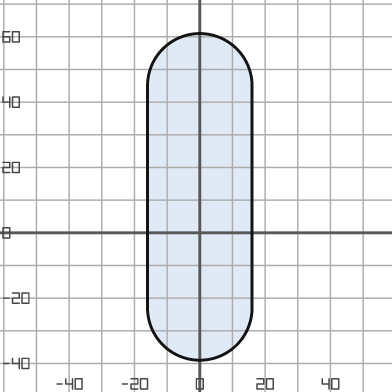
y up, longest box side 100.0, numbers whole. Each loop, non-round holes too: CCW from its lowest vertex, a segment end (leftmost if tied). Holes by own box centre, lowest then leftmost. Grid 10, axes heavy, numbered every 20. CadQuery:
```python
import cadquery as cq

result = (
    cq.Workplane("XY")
    .moveTo(-16.0, -23.0)
    .threePointArc((0.0, -39.0), (16.0, -23.0))
    .lineTo(16.0, 45.0)
    .threePointArc((0.0, 61.0), (-16.0, 45.0))
    .close()
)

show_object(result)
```